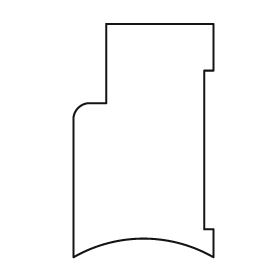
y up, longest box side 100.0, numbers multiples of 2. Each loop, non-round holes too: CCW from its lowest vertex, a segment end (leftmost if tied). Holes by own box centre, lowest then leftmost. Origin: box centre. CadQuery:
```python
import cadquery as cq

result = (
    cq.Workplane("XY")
    .moveTo(-30.0, -50.0)
    .threePointArc((0.0, -42.0), (30.0, -50.0))
    .lineTo(30.0, -38.0)
    .lineTo(26.0, -38.0)
    .lineTo(26.0, 30.0)
    .lineTo(30.0, 30.0)
    .lineTo(30.0, 50.0)
    .lineTo(-16.0, 50.0)
    .lineTo(-16.0, 16.0)
    .lineTo(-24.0, 16.0)
    .threePointArc((-28.0, 14.0), (-30.0, 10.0))
    .close()
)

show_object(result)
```